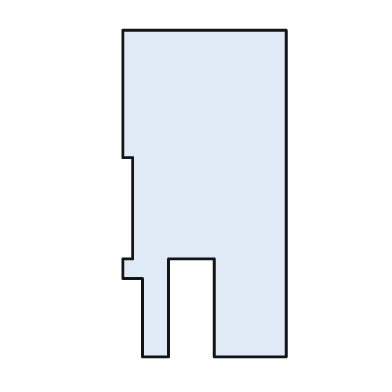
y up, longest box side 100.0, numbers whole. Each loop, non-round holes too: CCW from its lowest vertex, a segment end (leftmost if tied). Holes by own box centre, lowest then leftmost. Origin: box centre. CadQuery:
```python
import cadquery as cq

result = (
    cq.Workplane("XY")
    .moveTo(-19.0, -50.0)
    .lineTo(-11.0, -50.0)
    .lineTo(-11.0, -20.0)
    .lineTo(3.0, -20.0)
    .lineTo(3.0, -50.0)
    .lineTo(25.0, -50.0)
    .lineTo(25.0, 50.0)
    .lineTo(-25.0, 50.0)
    .lineTo(-25.0, 11.0)
    .lineTo(-22.0, 11.0)
    .lineTo(-22.0, -20.0)
    .lineTo(-25.0, -20.0)
    .lineTo(-25.0, -26.0)
    .lineTo(-19.0, -26.0)
    .close()
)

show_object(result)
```